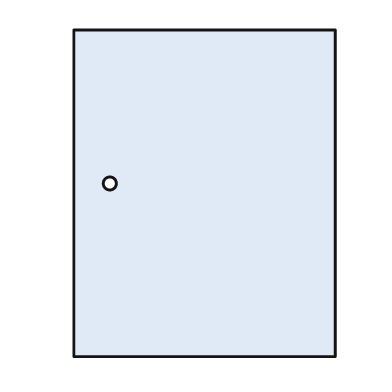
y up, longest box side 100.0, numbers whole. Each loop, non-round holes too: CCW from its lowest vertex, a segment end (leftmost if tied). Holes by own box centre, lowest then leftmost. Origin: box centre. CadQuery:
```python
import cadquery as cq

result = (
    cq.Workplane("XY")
    .moveTo(-40.0, -50.0)
    .lineTo(40.0, -50.0)
    .lineTo(40.0, 50.0)
    .lineTo(-40.0, 50.0)
    .close()
    .moveTo(-29.0, 3.0)
    .circle(2.0)
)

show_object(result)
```